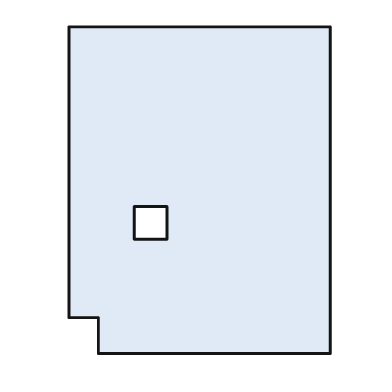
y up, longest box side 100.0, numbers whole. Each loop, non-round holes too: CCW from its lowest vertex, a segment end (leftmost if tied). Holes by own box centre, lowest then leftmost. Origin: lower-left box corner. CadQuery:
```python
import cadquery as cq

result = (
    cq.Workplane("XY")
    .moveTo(9.0, 0.0)
    .lineTo(80.0, 0.0)
    .lineTo(80.0, 100.0)
    .lineTo(0.0, 100.0)
    .lineTo(0.0, 11.0)
    .lineTo(9.0, 11.0)
    .close()
    .moveTo(20.0, 35.0)
    .lineTo(30.0, 35.0)
    .lineTo(30.0, 45.0)
    .lineTo(20.0, 45.0)
    .close()
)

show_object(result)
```